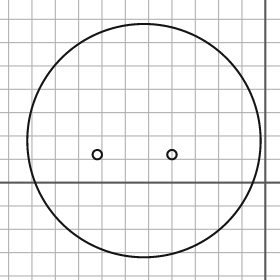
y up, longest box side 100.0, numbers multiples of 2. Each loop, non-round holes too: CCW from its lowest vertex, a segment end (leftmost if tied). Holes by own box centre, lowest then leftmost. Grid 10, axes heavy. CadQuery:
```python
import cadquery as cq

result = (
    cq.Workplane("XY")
    .moveTo(-52.0, 18.0)
    .circle(50.0)
    .moveTo(-72.0, 12.0)
    .circle(2.0)
    .moveTo(-40.0, 12.0)
    .circle(2.0)
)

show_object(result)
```